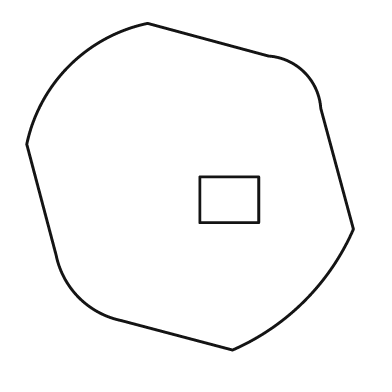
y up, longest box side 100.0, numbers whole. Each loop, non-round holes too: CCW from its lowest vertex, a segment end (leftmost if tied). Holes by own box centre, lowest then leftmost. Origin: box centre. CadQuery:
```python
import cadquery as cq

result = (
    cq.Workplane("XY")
    .moveTo(13.0, -50.0)
    .threePointArc((35.0, -35.0), (50.0, -13.0))
    .lineTo(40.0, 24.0)
    .threePointArc((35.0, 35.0), (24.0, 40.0))
    .lineTo(-13.0, 50.0)
    .threePointArc((-37.0, 37.0), (-50.0, 13.0))
    .lineTo(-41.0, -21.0)
    .threePointArc((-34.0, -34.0), (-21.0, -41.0))
    .close()
    .moveTo(3.0, -11.0)
    .lineTo(21.0, -11.0)
    .lineTo(21.0, 3.0)
    .lineTo(3.0, 3.0)
    .close()
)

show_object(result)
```